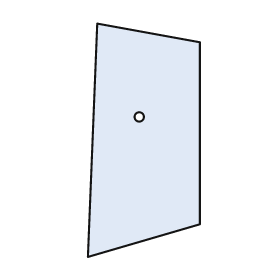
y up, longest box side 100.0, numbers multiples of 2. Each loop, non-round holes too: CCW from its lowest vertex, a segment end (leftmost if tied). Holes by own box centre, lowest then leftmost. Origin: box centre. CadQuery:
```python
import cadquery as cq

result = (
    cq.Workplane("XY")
    .moveTo(-24.0, -50.0)
    .lineTo(24.0, -36.0)
    .lineTo(24.0, 42.0)
    .lineTo(-20.0, 50.0)
    .close()
    .moveTo(-2.0, 10.0)
    .circle(2.0)
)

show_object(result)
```